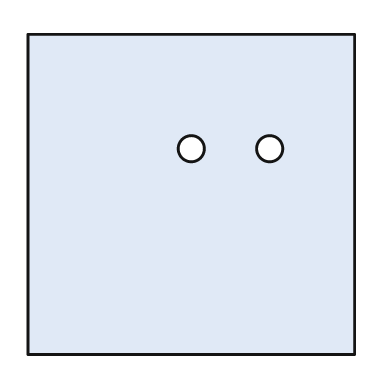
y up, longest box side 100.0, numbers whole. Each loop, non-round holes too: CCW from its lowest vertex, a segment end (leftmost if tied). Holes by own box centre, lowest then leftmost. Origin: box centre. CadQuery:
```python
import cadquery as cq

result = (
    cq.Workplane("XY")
    .moveTo(-50.0, -49.0)
    .lineTo(50.0, -49.0)
    .lineTo(50.0, 49.0)
    .lineTo(-50.0, 49.0)
    .close()
    .moveTo(0.0, 14.0)
    .circle(4.0)
    .moveTo(24.0, 14.0)
    .circle(4.0)
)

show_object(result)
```